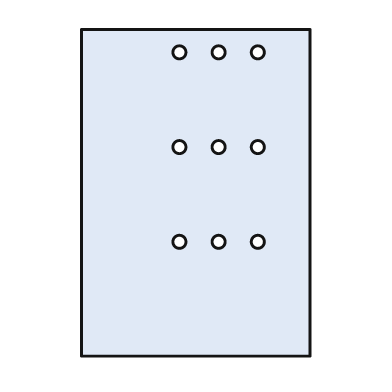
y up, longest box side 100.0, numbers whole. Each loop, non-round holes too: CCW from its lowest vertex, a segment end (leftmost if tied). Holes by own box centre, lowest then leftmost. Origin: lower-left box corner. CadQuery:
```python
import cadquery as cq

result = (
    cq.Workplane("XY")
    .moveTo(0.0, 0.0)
    .lineTo(70.0, 0.0)
    .lineTo(70.0, 100.0)
    .lineTo(0.0, 100.0)
    .close()
    .moveTo(30.0, 35.0)
    .circle(2.0)
    .moveTo(42.0, 35.0)
    .circle(2.0)
    .moveTo(54.0, 35.0)
    .circle(2.0)
    .moveTo(30.0, 64.0)
    .circle(2.0)
    .moveTo(42.0, 64.0)
    .circle(2.0)
    .moveTo(54.0, 64.0)
    .circle(2.0)
    .moveTo(30.0, 93.0)
    .circle(2.0)
    .moveTo(42.0, 93.0)
    .circle(2.0)
    .moveTo(54.0, 93.0)
    .circle(2.0)
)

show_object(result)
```